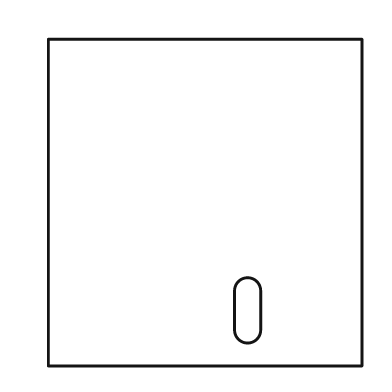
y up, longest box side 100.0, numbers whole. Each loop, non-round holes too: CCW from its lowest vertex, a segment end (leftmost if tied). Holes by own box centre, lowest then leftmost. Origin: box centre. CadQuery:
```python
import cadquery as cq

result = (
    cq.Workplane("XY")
    .moveTo(-48.0, -50.0)
    .lineTo(48.0, -50.0)
    .lineTo(48.0, 50.0)
    .lineTo(-48.0, 50.0)
    .close()
    .moveTo(9.0, -39.0)
    .threePointArc((13.0, -43.0), (17.0, -39.0))
    .lineTo(17.0, -27.0)
    .threePointArc((13.0, -23.0), (9.0, -27.0))
    .close()
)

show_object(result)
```